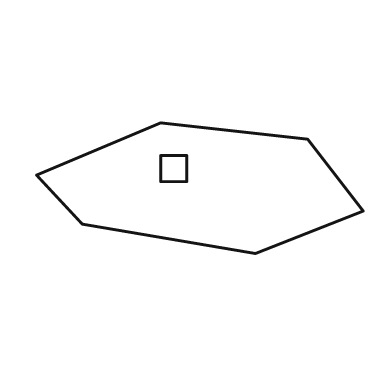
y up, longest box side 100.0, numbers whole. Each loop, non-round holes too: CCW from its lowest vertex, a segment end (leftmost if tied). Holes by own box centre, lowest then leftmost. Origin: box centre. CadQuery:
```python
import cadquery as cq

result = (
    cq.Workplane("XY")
    .moveTo(17.0, -20.0)
    .lineTo(50.0, -7.0)
    .lineTo(33.0, 15.0)
    .lineTo(-12.0, 20.0)
    .lineTo(-50.0, 4.0)
    .lineTo(-36.0, -11.0)
    .close()
    .moveTo(-12.0, 2.0)
    .lineTo(-4.0, 2.0)
    .lineTo(-4.0, 10.0)
    .lineTo(-12.0, 10.0)
    .close()
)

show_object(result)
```